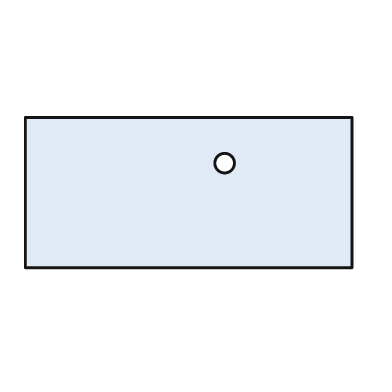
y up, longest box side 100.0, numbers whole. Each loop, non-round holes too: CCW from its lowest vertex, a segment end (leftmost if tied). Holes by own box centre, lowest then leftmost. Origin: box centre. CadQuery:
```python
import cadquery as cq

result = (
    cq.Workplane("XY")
    .moveTo(-50.0, -23.0)
    .lineTo(50.0, -23.0)
    .lineTo(50.0, 23.0)
    .lineTo(-50.0, 23.0)
    .close()
    .moveTo(11.0, 9.0)
    .circle(3.0)
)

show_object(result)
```